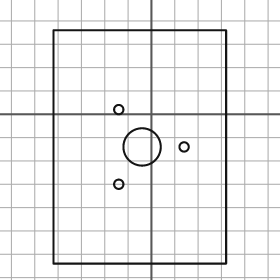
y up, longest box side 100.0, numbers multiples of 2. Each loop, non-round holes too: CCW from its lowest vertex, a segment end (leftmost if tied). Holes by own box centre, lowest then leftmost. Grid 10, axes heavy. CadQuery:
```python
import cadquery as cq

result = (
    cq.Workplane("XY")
    .moveTo(-42.0, -64.0)
    .lineTo(32.0, -64.0)
    .lineTo(32.0, 36.0)
    .lineTo(-42.0, 36.0)
    .close()
    .moveTo(-14.0, -30.0)
    .circle(2.0)
    .moveTo(-4.0, -14.0)
    .circle(8.0)
    .moveTo(14.0, -14.0)
    .circle(2.0)
    .moveTo(-14.0, 2.0)
    .circle(2.0)
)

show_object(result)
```